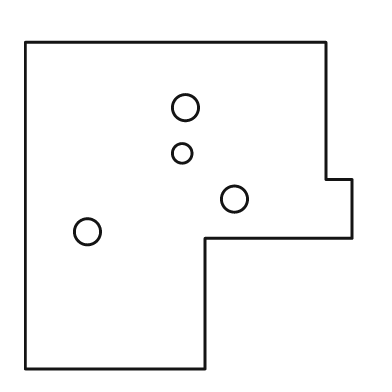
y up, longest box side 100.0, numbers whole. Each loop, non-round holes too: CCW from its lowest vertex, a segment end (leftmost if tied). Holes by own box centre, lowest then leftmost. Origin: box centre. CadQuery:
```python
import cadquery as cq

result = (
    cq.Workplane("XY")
    .moveTo(-50.0, -50.0)
    .lineTo(5.0, -50.0)
    .lineTo(5.0, -10.0)
    .lineTo(50.0, -10.0)
    .lineTo(50.0, 8.0)
    .lineTo(42.0, 8.0)
    .lineTo(42.0, 50.0)
    .lineTo(-50.0, 50.0)
    .close()
    .moveTo(-31.0, -8.0)
    .circle(4.0)
    .moveTo(14.0, 2.0)
    .circle(4.0)
    .moveTo(-2.0, 16.0)
    .circle(3.0)
    .moveTo(-1.0, 30.0)
    .circle(4.0)
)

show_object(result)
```